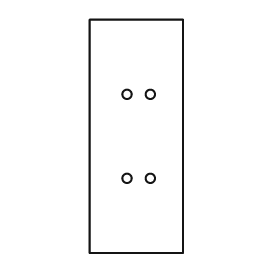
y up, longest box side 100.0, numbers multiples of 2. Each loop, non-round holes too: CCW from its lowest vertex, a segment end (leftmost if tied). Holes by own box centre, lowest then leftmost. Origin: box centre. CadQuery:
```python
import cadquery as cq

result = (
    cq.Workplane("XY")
    .moveTo(-20.0, -50.0)
    .lineTo(20.0, -50.0)
    .lineTo(20.0, 50.0)
    .lineTo(-20.0, 50.0)
    .close()
    .moveTo(-4.0, -18.0)
    .circle(2.0)
    .moveTo(6.0, -18.0)
    .circle(2.0)
    .moveTo(-4.0, 18.0)
    .circle(2.0)
    .moveTo(6.0, 18.0)
    .circle(2.0)
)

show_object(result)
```